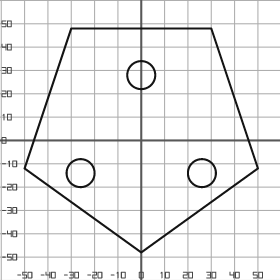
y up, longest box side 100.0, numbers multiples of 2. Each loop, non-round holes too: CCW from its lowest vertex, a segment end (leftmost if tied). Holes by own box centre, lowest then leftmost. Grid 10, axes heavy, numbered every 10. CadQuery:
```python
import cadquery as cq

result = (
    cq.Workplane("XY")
    .moveTo(0.0, -48.0)
    .lineTo(50.0, -12.0)
    .lineTo(30.0, 48.0)
    .lineTo(-30.0, 48.0)
    .lineTo(-50.0, -12.0)
    .close()
    .moveTo(-26.0, -14.0)
    .circle(6.0)
    .moveTo(26.0, -14.0)
    .circle(6.0)
    .moveTo(0.0, 28.0)
    .circle(6.0)
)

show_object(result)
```